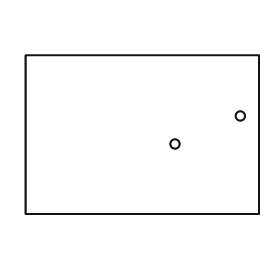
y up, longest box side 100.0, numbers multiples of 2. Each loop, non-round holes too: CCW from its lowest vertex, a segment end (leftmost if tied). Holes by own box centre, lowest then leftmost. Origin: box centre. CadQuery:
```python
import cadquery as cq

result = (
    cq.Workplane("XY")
    .moveTo(-50.0, -34.0)
    .lineTo(50.0, -34.0)
    .lineTo(50.0, 34.0)
    .lineTo(-50.0, 34.0)
    .close()
    .moveTo(14.0, -4.0)
    .circle(2.0)
    .moveTo(42.0, 8.0)
    .circle(2.0)
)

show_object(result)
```